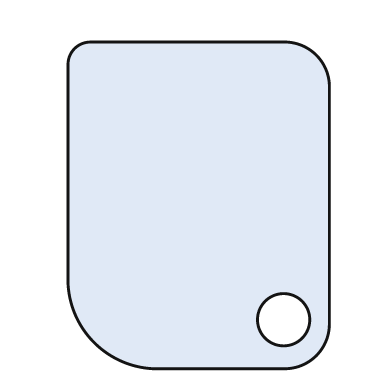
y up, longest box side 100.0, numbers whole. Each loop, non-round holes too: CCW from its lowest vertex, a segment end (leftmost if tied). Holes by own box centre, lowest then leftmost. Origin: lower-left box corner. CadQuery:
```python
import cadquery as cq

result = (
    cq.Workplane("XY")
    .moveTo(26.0, 0.0)
    .lineTo(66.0, 0.0)
    .threePointArc((76.0, 4.0), (80.0, 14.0))
    .lineTo(80.0, 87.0)
    .threePointArc((76.0, 96.0), (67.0, 100.0))
    .lineTo(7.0, 100.0)
    .threePointArc((2.0, 98.0), (0.0, 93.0))
    .lineTo(0.0, 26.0)
    .threePointArc((8.0, 8.0), (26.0, 0.0))
    .close()
    .moveTo(66.0, 15.0)
    .circle(8.0)
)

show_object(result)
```